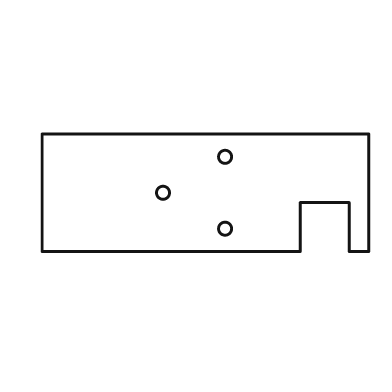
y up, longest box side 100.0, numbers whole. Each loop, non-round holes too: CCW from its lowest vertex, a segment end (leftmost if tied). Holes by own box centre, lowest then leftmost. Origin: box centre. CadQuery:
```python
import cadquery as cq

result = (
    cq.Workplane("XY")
    .moveTo(-50.0, -18.0)
    .lineTo(29.0, -18.0)
    .lineTo(29.0, -3.0)
    .lineTo(44.0, -3.0)
    .lineTo(44.0, -18.0)
    .lineTo(50.0, -18.0)
    .lineTo(50.0, 18.0)
    .lineTo(-50.0, 18.0)
    .close()
    .moveTo(6.0, -11.0)
    .circle(2.0)
    .moveTo(-13.0, 0.0)
    .circle(2.0)
    .moveTo(6.0, 11.0)
    .circle(2.0)
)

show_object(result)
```